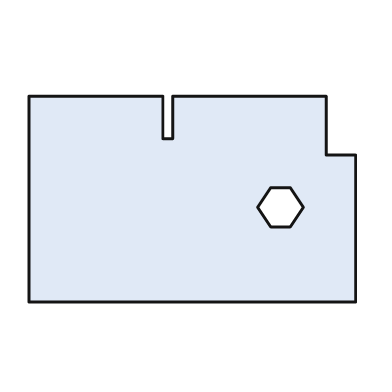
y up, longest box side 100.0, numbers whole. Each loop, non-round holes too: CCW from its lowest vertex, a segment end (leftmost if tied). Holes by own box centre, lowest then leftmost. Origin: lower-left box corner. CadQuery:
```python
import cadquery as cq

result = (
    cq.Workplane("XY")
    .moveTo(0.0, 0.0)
    .lineTo(100.0, 0.0)
    .lineTo(100.0, 45.0)
    .lineTo(91.0, 45.0)
    .lineTo(91.0, 63.0)
    .lineTo(44.0, 63.0)
    .lineTo(44.0, 50.0)
    .lineTo(41.0, 50.0)
    .lineTo(41.0, 63.0)
    .lineTo(0.0, 63.0)
    .close()
    .moveTo(74.0, 23.0)
    .lineTo(80.0, 23.0)
    .lineTo(84.0, 29.0)
    .lineTo(80.0, 35.0)
    .lineTo(74.0, 35.0)
    .lineTo(70.0, 29.0)
    .close()
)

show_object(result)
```